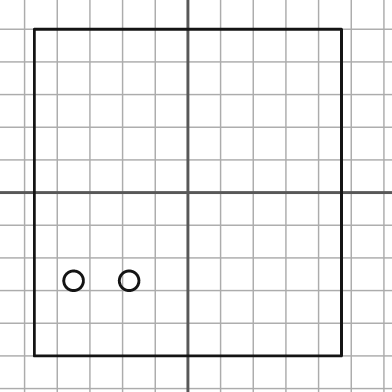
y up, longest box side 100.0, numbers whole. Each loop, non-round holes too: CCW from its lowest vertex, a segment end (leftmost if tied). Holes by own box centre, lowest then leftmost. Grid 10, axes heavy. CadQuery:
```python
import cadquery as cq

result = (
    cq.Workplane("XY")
    .moveTo(-47.0, -50.0)
    .lineTo(47.0, -50.0)
    .lineTo(47.0, 50.0)
    .lineTo(-47.0, 50.0)
    .close()
    .moveTo(-35.0, -27.0)
    .circle(3.0)
    .moveTo(-18.0, -27.0)
    .circle(3.0)
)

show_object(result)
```